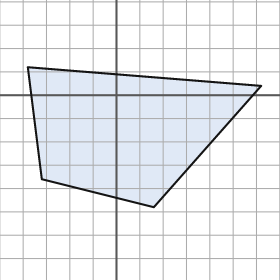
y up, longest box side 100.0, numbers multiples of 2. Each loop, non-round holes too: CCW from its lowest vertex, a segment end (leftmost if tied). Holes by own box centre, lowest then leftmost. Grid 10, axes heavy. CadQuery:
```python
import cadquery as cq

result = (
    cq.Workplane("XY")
    .moveTo(16.0, -48.0)
    .lineTo(62.0, 4.0)
    .lineTo(-38.0, 12.0)
    .lineTo(-32.0, -36.0)
    .close()
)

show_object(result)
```